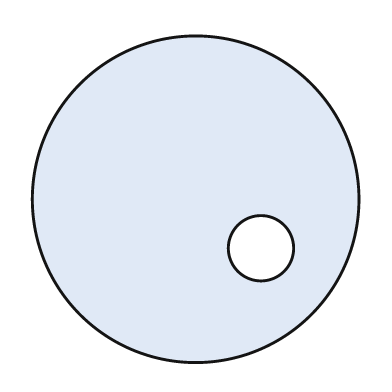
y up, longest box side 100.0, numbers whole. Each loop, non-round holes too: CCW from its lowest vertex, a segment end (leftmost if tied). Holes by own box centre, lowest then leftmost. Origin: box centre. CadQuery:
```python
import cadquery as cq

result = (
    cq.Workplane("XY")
    .moveTo(0.0, 0.0)
    .circle(50.0)
    .moveTo(20.0, -15.0)
    .circle(10.0)
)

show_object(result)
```